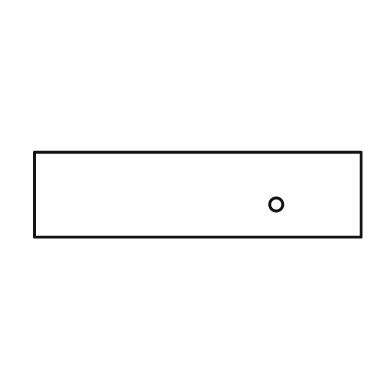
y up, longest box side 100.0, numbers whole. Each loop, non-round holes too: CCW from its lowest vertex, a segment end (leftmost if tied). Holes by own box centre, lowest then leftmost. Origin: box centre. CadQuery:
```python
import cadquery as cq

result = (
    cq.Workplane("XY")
    .moveTo(-50.0, -13.0)
    .lineTo(50.0, -13.0)
    .lineTo(50.0, 13.0)
    .lineTo(-50.0, 13.0)
    .close()
    .moveTo(24.0, -3.0)
    .circle(2.0)
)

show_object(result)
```